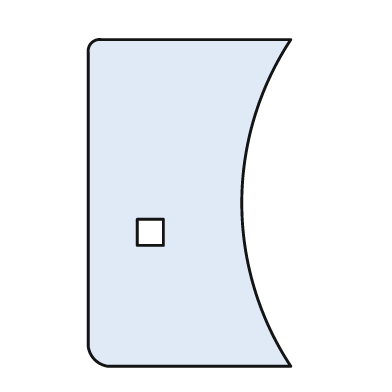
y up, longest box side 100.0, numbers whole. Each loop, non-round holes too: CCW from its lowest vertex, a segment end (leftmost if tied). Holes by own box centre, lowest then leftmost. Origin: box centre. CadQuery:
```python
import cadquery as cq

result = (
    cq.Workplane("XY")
    .moveTo(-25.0, -50.0)
    .lineTo(31.0, -50.0)
    .threePointArc((16.0, 0.0), (31.0, 50.0))
    .lineTo(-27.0, 50.0)
    .threePointArc((-30.0, 49.0), (-31.0, 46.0))
    .lineTo(-31.0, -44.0)
    .threePointArc((-29.0, -48.0), (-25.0, -50.0))
    .close()
    .moveTo(-16.0, -13.0)
    .lineTo(-8.0, -13.0)
    .lineTo(-8.0, -5.0)
    .lineTo(-16.0, -5.0)
    .close()
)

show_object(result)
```